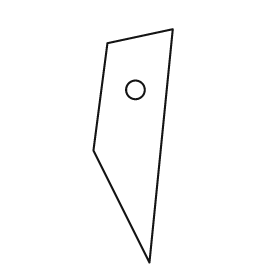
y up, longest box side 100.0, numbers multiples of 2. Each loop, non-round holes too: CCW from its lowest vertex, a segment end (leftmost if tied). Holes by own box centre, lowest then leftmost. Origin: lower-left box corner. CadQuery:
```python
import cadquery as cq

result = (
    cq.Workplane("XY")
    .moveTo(24.0, 0.0)
    .lineTo(34.0, 100.0)
    .lineTo(6.0, 94.0)
    .lineTo(0.0, 48.0)
    .close()
    .moveTo(18.0, 74.0)
    .circle(4.0)
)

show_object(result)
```